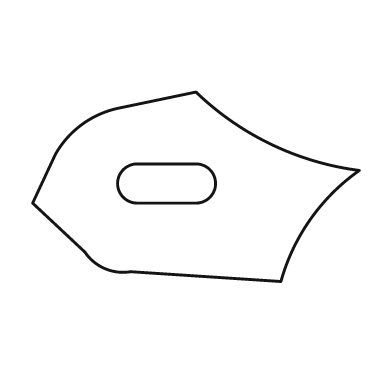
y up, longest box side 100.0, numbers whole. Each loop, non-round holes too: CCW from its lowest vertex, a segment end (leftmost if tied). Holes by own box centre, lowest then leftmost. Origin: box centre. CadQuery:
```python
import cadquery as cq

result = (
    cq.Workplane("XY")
    .moveTo(26.0, -29.0)
    .threePointArc((35.0, -10.0), (50.0, 5.0))
    .threePointArc((23.0, 13.0), (0.0, 29.0))
    .lineTo(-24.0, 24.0)
    .threePointArc((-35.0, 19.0), (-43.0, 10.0))
    .lineTo(-50.0, -5.0)
    .lineTo(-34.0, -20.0)
    .threePointArc((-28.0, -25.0), (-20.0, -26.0))
    .close()
    .moveTo(-18.0, -5.0)
    .lineTo(0.0, -5.0)
    .threePointArc((6.0, 1.0), (0.0, 7.0))
    .lineTo(-18.0, 7.0)
    .threePointArc((-24.0, 1.0), (-18.0, -5.0))
    .close()
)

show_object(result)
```